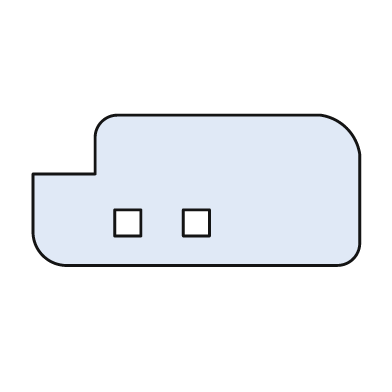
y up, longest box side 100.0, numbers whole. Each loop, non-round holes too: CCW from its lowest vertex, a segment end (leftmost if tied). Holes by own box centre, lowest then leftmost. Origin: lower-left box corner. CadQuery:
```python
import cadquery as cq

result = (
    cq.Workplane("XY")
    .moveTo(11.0, 0.0)
    .lineTo(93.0, 0.0)
    .threePointArc((98.0, 2.0), (100.0, 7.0))
    .lineTo(100.0, 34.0)
    .threePointArc((96.0, 42.0), (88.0, 46.0))
    .lineTo(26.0, 46.0)
    .threePointArc((21.0, 44.0), (19.0, 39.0))
    .lineTo(19.0, 28.0)
    .lineTo(0.0, 28.0)
    .lineTo(0.0, 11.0)
    .threePointArc((3.0, 3.0), (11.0, 0.0))
    .close()
    .moveTo(25.0, 9.0)
    .lineTo(33.0, 9.0)
    .lineTo(33.0, 17.0)
    .lineTo(25.0, 17.0)
    .close()
    .moveTo(46.0, 9.0)
    .lineTo(54.0, 9.0)
    .lineTo(54.0, 17.0)
    .lineTo(46.0, 17.0)
    .close()
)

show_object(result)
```